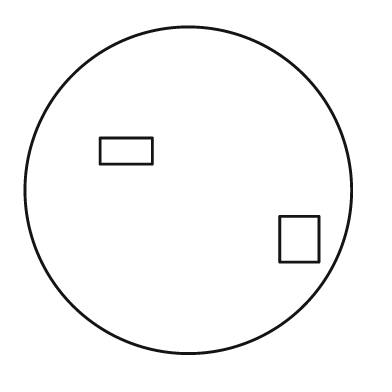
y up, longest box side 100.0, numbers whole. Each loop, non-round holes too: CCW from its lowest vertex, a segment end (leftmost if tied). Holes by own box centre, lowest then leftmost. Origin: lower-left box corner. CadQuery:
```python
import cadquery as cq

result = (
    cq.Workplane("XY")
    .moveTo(50.0, 50.0)
    .circle(50.0)
    .moveTo(78.0, 28.0)
    .lineTo(90.0, 28.0)
    .lineTo(90.0, 42.0)
    .lineTo(78.0, 42.0)
    .close()
    .moveTo(23.0, 58.0)
    .lineTo(39.0, 58.0)
    .lineTo(39.0, 66.0)
    .lineTo(23.0, 66.0)
    .close()
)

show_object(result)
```